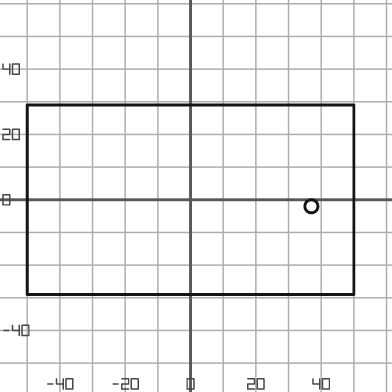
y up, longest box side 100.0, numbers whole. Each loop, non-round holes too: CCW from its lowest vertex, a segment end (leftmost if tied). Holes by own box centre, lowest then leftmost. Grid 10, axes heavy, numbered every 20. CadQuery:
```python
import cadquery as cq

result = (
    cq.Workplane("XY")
    .moveTo(-50.0, -29.0)
    .lineTo(50.0, -29.0)
    .lineTo(50.0, 29.0)
    .lineTo(-50.0, 29.0)
    .close()
    .moveTo(37.0, -2.0)
    .circle(2.0)
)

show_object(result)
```